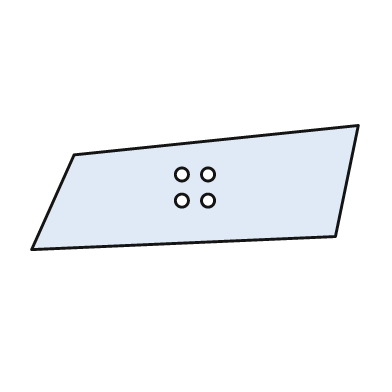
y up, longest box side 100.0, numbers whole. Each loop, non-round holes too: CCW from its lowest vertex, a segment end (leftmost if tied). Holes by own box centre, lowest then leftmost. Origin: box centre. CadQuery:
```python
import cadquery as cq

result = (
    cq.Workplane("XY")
    .moveTo(-50.0, -19.0)
    .lineTo(43.0, -15.0)
    .lineTo(50.0, 19.0)
    .lineTo(-37.0, 10.0)
    .close()
    .moveTo(-4.0, -4.0)
    .circle(2.0)
    .moveTo(4.0, -4.0)
    .circle(2.0)
    .moveTo(-4.0, 4.0)
    .circle(2.0)
    .moveTo(4.0, 4.0)
    .circle(2.0)
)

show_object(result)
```